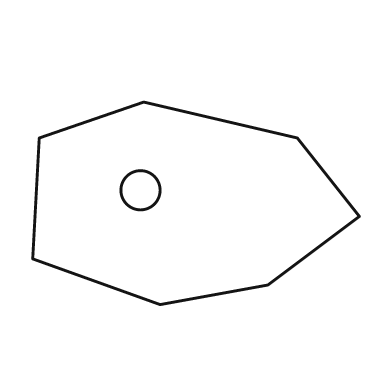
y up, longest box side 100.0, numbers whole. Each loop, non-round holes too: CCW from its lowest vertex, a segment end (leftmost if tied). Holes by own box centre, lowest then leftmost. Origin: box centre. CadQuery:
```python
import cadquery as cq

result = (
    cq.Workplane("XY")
    .moveTo(-11.0, -31.0)
    .lineTo(22.0, -25.0)
    .lineTo(50.0, -4.0)
    .lineTo(31.0, 20.0)
    .lineTo(-16.0, 31.0)
    .lineTo(-48.0, 20.0)
    .lineTo(-50.0, -17.0)
    .close()
    .moveTo(-17.0, 4.0)
    .circle(6.0)
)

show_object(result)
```